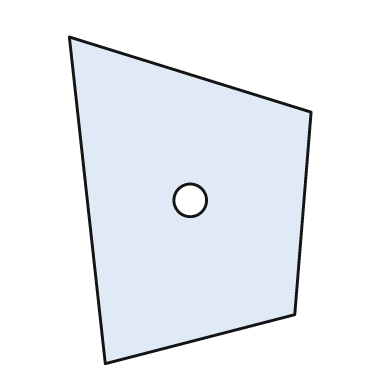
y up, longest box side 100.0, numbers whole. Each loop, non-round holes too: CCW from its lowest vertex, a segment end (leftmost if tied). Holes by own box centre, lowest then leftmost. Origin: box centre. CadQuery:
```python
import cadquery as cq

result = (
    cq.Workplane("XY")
    .moveTo(-26.0, -50.0)
    .lineTo(32.0, -35.0)
    .lineTo(37.0, 27.0)
    .lineTo(-37.0, 50.0)
    .close()
    .moveTo(0.0, 0.0)
    .circle(5.0)
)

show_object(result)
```